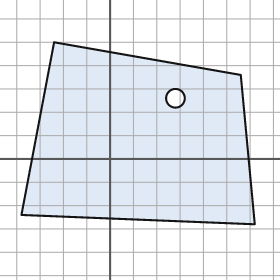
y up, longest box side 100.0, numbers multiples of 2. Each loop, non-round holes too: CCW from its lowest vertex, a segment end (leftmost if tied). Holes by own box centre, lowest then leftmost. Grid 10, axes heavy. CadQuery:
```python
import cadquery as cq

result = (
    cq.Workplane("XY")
    .moveTo(62.0, -28.0)
    .lineTo(56.0, 36.0)
    .lineTo(-24.0, 50.0)
    .lineTo(-38.0, -24.0)
    .close()
    .moveTo(28.0, 26.0)
    .circle(4.0)
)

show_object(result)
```